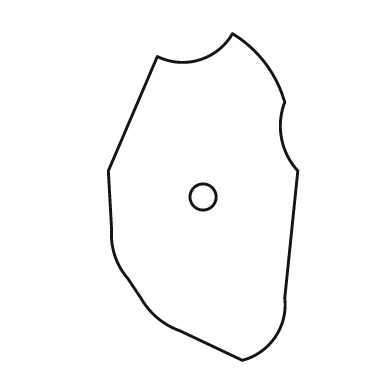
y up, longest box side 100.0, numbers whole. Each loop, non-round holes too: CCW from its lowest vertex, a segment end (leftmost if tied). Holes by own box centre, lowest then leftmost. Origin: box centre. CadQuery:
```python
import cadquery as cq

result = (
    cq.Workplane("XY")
    .moveTo(12.0, -50.0)
    .threePointArc((22.0, -43.0), (25.0, -31.0))
    .lineTo(29.0, 8.0)
    .threePointArc((24.0, 18.0), (25.0, 29.0))
    .threePointArc((19.0, 41.0), (9.0, 50.0))
    .threePointArc((-1.0, 42.0), (-14.0, 43.0))
    .lineTo(-29.0, 8.0)
    .lineTo(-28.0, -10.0)
    .threePointArc((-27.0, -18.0), (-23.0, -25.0))
    .lineTo(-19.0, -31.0)
    .threePointArc((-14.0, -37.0), (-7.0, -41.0))
    .close()
    .moveTo(0.0, 0.0)
    .circle(4.0)
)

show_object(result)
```